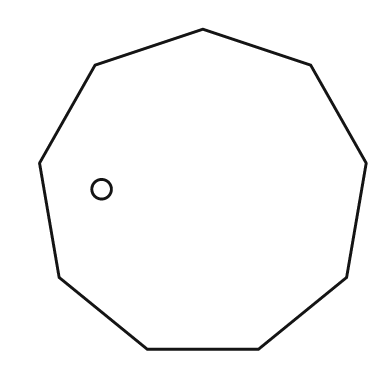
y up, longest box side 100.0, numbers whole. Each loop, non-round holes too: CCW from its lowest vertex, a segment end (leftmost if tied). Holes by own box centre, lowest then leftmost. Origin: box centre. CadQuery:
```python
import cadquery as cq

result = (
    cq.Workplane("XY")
    .moveTo(-17.0, -49.0)
    .lineTo(17.0, -49.0)
    .lineTo(44.0, -27.0)
    .lineTo(50.0, 8.0)
    .lineTo(33.0, 38.0)
    .lineTo(0.0, 49.0)
    .lineTo(-33.0, 38.0)
    .lineTo(-50.0, 8.0)
    .lineTo(-44.0, -27.0)
    .close()
    .moveTo(-31.0, 0.0)
    .circle(3.0)
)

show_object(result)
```